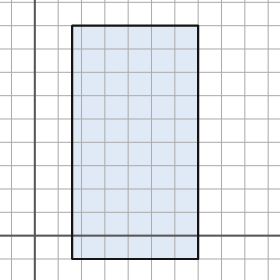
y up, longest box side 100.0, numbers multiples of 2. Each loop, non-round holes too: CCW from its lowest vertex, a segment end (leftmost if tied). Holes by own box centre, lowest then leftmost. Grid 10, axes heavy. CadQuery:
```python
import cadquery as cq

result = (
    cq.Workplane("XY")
    .moveTo(16.0, -10.0)
    .lineTo(70.0, -10.0)
    .lineTo(70.0, 90.0)
    .lineTo(16.0, 90.0)
    .close()
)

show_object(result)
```